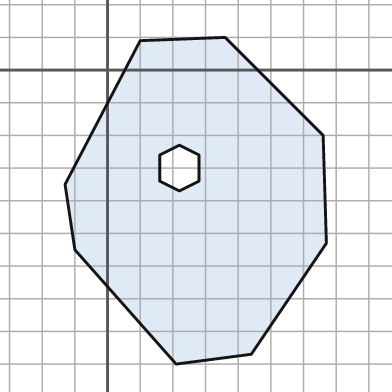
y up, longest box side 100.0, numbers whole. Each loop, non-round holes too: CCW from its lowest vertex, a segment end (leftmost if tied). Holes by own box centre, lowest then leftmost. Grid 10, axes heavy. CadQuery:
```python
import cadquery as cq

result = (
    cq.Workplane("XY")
    .moveTo(21.0, -90.0)
    .lineTo(44.0, -87.0)
    .lineTo(67.0, -53.0)
    .lineTo(66.0, -20.0)
    .lineTo(36.0, 10.0)
    .lineTo(10.0, 9.0)
    .lineTo(-13.0, -35.0)
    .lineTo(-10.0, -55.0)
    .close()
    .moveTo(22.0, -37.0)
    .lineTo(28.0, -34.0)
    .lineTo(28.0, -26.0)
    .lineTo(22.0, -23.0)
    .lineTo(16.0, -26.0)
    .lineTo(16.0, -34.0)
    .close()
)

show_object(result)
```